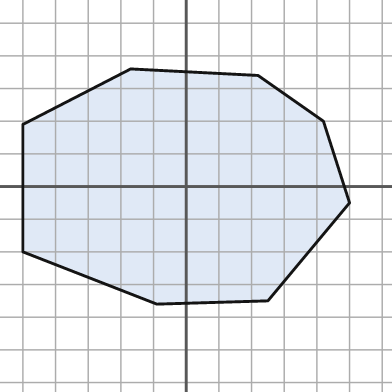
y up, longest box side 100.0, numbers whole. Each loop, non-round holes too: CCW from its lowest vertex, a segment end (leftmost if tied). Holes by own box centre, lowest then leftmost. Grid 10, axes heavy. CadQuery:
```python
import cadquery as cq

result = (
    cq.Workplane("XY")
    .moveTo(-9.0, -36.0)
    .lineTo(25.0, -35.0)
    .lineTo(50.0, -5.0)
    .lineTo(42.0, 20.0)
    .lineTo(22.0, 34.0)
    .lineTo(-17.0, 36.0)
    .lineTo(-50.0, 19.0)
    .lineTo(-50.0, -20.0)
    .close()
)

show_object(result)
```